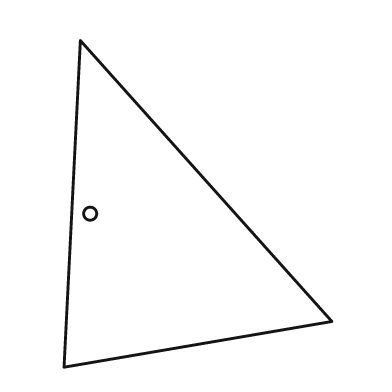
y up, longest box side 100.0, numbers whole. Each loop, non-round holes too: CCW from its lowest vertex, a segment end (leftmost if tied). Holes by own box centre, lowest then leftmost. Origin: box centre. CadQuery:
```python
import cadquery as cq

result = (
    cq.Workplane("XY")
    .moveTo(-41.0, -50.0)
    .lineTo(41.0, -36.0)
    .lineTo(-36.0, 50.0)
    .close()
    .moveTo(-33.0, -3.0)
    .circle(2.0)
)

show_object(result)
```